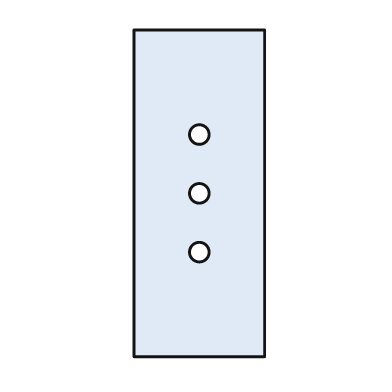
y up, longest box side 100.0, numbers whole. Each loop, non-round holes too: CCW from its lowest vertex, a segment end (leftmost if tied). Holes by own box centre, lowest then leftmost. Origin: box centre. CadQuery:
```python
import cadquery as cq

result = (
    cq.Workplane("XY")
    .moveTo(-20.0, -50.0)
    .lineTo(20.0, -50.0)
    .lineTo(20.0, 50.0)
    .lineTo(-20.0, 50.0)
    .close()
    .moveTo(0.0, -18.0)
    .circle(3.0)
    .moveTo(0.0, 0.0)
    .circle(3.0)
    .moveTo(0.0, 18.0)
    .circle(3.0)
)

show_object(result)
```